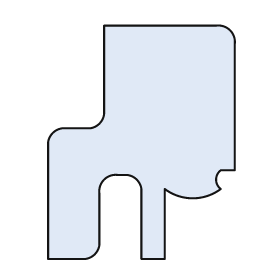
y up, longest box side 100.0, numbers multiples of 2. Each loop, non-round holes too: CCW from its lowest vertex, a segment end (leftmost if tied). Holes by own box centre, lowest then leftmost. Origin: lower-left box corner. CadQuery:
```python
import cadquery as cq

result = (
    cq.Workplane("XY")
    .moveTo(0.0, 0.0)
    .lineTo(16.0, 0.0)
    .threePointArc((20.0, 2.0), (22.0, 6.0))
    .lineTo(22.0, 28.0)
    .threePointArc((24.0, 34.0), (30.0, 36.0))
    .lineTo(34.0, 36.0)
    .threePointArc((38.0, 34.0), (40.0, 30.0))
    .lineTo(40.0, 0.0)
    .lineTo(50.0, 0.0)
    .lineTo(50.0, 30.0)
    .threePointArc((62.0, 26.0), (74.0, 30.0))
    .threePointArc((72.0, 34.0), (74.0, 38.0))
    .lineTo(80.0, 38.0)
    .lineTo(80.0, 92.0)
    .threePointArc((78.0, 98.0), (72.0, 100.0))
    .lineTo(24.0, 100.0)
    .lineTo(24.0, 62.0)
    .threePointArc((22.0, 58.0), (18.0, 56.0))
    .lineTo(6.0, 56.0)
    .threePointArc((2.0, 54.0), (0.0, 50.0))
    .close()
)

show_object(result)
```